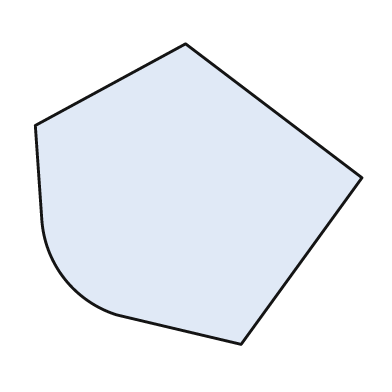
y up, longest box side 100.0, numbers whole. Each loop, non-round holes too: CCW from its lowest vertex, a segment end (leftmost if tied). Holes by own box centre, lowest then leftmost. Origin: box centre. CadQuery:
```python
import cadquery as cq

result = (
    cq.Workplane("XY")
    .moveTo(13.0, -46.0)
    .lineTo(50.0, 5.0)
    .lineTo(-4.0, 46.0)
    .lineTo(-50.0, 21.0)
    .lineTo(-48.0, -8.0)
    .threePointArc((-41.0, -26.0), (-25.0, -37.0))
    .close()
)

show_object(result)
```